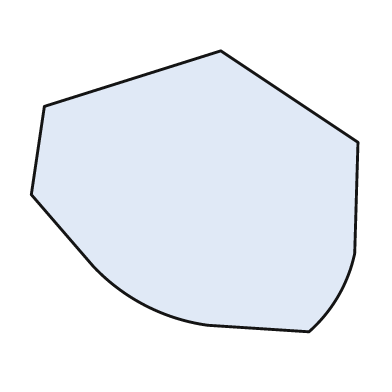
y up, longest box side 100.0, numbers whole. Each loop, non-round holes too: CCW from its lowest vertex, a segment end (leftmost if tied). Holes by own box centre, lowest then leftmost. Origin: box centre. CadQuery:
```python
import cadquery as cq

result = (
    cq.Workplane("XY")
    .moveTo(35.0, -43.0)
    .threePointArc((44.0, -32.0), (49.0, -19.0))
    .lineTo(50.0, 15.0)
    .lineTo(8.0, 43.0)
    .lineTo(-46.0, 26.0)
    .lineTo(-50.0, -1.0)
    .lineTo(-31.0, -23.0)
    .threePointArc((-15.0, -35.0), (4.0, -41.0))
    .close()
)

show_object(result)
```